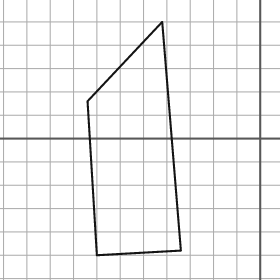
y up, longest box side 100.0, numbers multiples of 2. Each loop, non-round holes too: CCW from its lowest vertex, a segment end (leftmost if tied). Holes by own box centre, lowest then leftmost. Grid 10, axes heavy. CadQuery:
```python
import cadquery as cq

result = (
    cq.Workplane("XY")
    .moveTo(-70.0, -50.0)
    .lineTo(-34.0, -48.0)
    .lineTo(-42.0, 50.0)
    .lineTo(-74.0, 16.0)
    .close()
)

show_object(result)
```